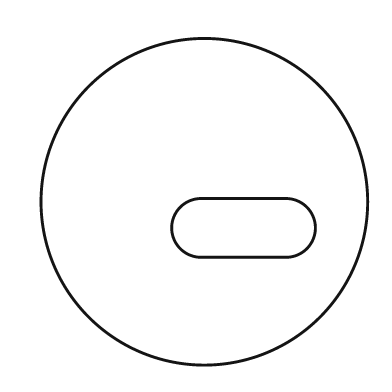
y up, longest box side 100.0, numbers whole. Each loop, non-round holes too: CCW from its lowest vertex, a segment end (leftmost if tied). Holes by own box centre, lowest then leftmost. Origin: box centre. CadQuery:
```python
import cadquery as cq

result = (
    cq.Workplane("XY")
    .moveTo(0.0, 0.0)
    .circle(50.0)
    .moveTo(-1.0, -17.0)
    .lineTo(25.0, -17.0)
    .threePointArc((34.0, -8.0), (25.0, 1.0))
    .lineTo(-1.0, 1.0)
    .threePointArc((-10.0, -8.0), (-1.0, -17.0))
    .close()
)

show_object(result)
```